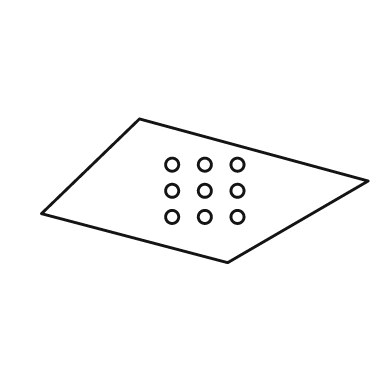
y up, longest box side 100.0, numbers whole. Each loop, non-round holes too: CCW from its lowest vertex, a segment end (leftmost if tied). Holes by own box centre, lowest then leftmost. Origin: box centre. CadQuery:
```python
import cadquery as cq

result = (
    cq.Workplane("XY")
    .moveTo(7.0, -22.0)
    .lineTo(50.0, 3.0)
    .lineTo(-20.0, 22.0)
    .lineTo(-50.0, -7.0)
    .close()
    .moveTo(-10.0, -8.0)
    .circle(2.0)
    .moveTo(0.0, -8.0)
    .circle(2.0)
    .moveTo(10.0, -8.0)
    .circle(2.0)
    .moveTo(-10.0, 0.0)
    .circle(2.0)
    .moveTo(0.0, 0.0)
    .circle(2.0)
    .moveTo(10.0, 0.0)
    .circle(2.0)
    .moveTo(-10.0, 8.0)
    .circle(2.0)
    .moveTo(0.0, 8.0)
    .circle(2.0)
    .moveTo(10.0, 8.0)
    .circle(2.0)
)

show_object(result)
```